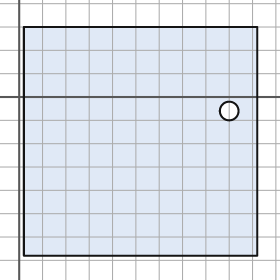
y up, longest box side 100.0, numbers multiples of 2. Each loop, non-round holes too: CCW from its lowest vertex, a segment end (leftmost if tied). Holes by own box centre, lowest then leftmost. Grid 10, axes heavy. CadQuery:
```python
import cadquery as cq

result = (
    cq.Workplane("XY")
    .moveTo(2.0, -68.0)
    .lineTo(102.0, -68.0)
    .lineTo(102.0, 30.0)
    .lineTo(2.0, 30.0)
    .close()
    .moveTo(90.0, -6.0)
    .circle(4.0)
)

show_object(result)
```